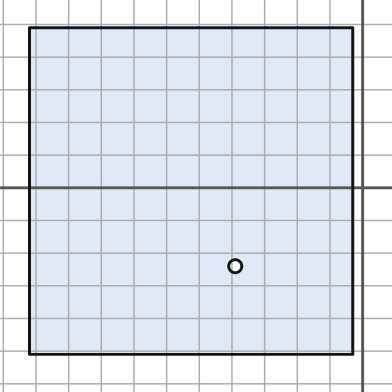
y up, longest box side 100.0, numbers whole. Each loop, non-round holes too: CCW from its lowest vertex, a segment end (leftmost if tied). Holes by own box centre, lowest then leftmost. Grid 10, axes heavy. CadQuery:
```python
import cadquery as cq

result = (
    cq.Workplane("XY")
    .moveTo(-102.0, -51.0)
    .lineTo(-3.0, -51.0)
    .lineTo(-3.0, 49.0)
    .lineTo(-102.0, 49.0)
    .close()
    .moveTo(-39.0, -24.0)
    .circle(2.0)
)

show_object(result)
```